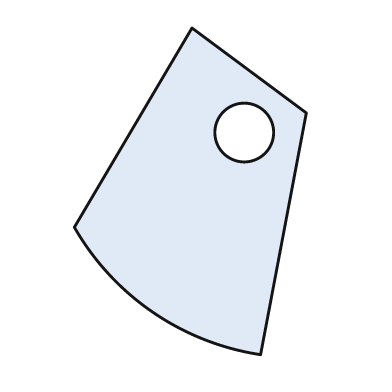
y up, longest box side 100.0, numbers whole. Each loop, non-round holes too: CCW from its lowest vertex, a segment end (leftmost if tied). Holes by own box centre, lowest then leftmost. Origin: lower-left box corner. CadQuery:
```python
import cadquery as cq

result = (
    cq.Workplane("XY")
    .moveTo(57.0, 0.0)
    .lineTo(71.0, 74.0)
    .lineTo(36.0, 100.0)
    .lineTo(0.0, 39.0)
    .threePointArc((24.0, 13.0), (57.0, 0.0))
    .close()
    .moveTo(52.0, 68.0)
    .circle(9.0)
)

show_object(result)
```